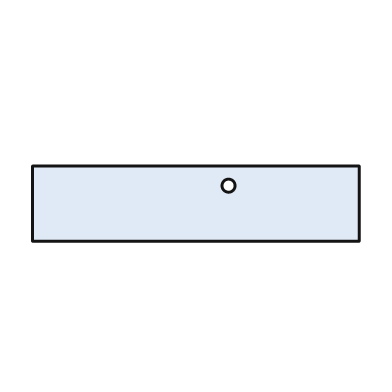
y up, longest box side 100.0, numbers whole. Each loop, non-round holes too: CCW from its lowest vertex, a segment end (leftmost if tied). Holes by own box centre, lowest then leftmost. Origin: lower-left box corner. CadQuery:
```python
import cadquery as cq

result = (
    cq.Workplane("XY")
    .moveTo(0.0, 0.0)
    .lineTo(100.0, 0.0)
    .lineTo(100.0, 23.0)
    .lineTo(0.0, 23.0)
    .close()
    .moveTo(60.0, 17.0)
    .circle(2.0)
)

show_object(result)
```